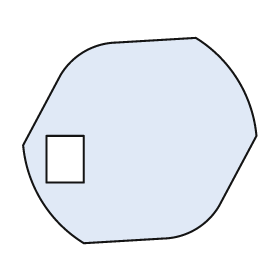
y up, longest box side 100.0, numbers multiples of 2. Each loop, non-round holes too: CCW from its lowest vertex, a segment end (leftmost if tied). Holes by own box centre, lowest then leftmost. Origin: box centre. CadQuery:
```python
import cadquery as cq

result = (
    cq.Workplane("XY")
    .moveTo(-24.0, -44.0)
    .lineTo(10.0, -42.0)
    .threePointArc((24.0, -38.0), (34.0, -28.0))
    .lineTo(50.0, 2.0)
    .threePointArc((42.0, 26.0), (24.0, 44.0))
    .lineTo(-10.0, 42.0)
    .threePointArc((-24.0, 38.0), (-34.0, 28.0))
    .lineTo(-50.0, -2.0)
    .threePointArc((-42.0, -26.0), (-24.0, -44.0))
    .close()
    .moveTo(-40.0, -18.0)
    .lineTo(-24.0, -18.0)
    .lineTo(-24.0, 2.0)
    .lineTo(-40.0, 2.0)
    .close()
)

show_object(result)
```